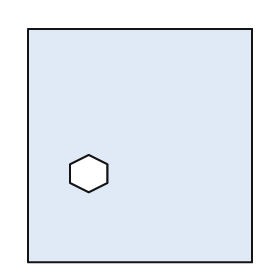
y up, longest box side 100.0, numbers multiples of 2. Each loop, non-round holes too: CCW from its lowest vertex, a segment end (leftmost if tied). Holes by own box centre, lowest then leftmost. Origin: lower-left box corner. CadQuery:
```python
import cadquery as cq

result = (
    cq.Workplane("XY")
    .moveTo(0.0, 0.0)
    .lineTo(96.0, 0.0)
    .lineTo(96.0, 100.0)
    .lineTo(0.0, 100.0)
    .close()
    .moveTo(26.0, 30.0)
    .lineTo(34.0, 34.0)
    .lineTo(34.0, 42.0)
    .lineTo(26.0, 46.0)
    .lineTo(18.0, 42.0)
    .lineTo(18.0, 34.0)
    .close()
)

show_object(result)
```